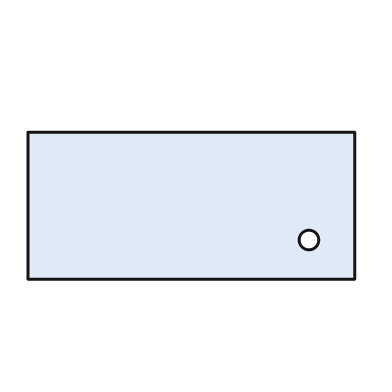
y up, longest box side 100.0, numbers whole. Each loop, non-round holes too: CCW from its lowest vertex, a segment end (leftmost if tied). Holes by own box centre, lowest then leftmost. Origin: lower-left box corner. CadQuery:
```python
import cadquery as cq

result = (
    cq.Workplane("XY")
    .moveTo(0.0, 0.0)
    .lineTo(100.0, 0.0)
    .lineTo(100.0, 45.0)
    .lineTo(0.0, 45.0)
    .close()
    .moveTo(86.0, 12.0)
    .circle(3.0)
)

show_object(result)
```